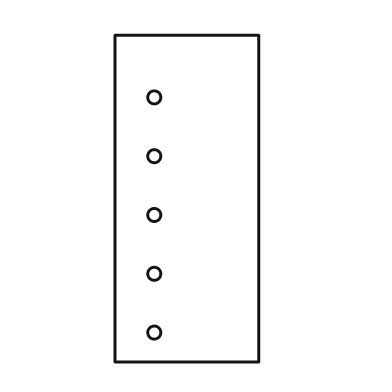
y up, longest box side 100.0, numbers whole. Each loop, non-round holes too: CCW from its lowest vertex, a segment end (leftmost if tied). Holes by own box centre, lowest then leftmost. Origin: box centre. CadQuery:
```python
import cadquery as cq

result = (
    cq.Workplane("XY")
    .moveTo(-22.0, -50.0)
    .lineTo(22.0, -50.0)
    .lineTo(22.0, 50.0)
    .lineTo(-22.0, 50.0)
    .close()
    .moveTo(-10.0, -41.0)
    .circle(2.0)
    .moveTo(-10.0, -23.0)
    .circle(2.0)
    .moveTo(-10.0, -5.0)
    .circle(2.0)
    .moveTo(-10.0, 13.0)
    .circle(2.0)
    .moveTo(-10.0, 31.0)
    .circle(2.0)
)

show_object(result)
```